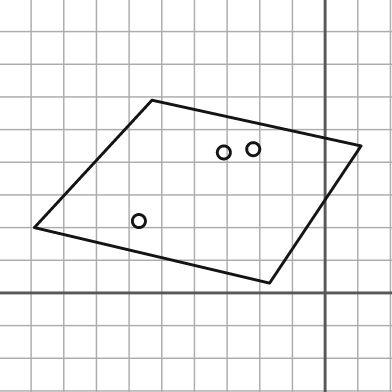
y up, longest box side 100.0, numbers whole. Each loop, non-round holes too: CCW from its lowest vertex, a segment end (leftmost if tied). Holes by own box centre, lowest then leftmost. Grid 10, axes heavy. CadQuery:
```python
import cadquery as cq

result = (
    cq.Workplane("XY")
    .moveTo(-17.0, 3.0)
    .lineTo(11.0, 45.0)
    .lineTo(-53.0, 59.0)
    .lineTo(-89.0, 20.0)
    .close()
    .moveTo(-57.0, 22.0)
    .circle(2.0)
    .moveTo(-31.0, 43.0)
    .circle(2.0)
    .moveTo(-22.0, 44.0)
    .circle(2.0)
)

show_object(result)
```